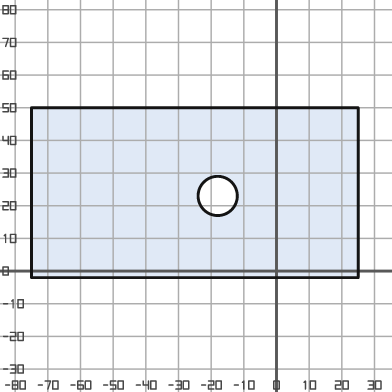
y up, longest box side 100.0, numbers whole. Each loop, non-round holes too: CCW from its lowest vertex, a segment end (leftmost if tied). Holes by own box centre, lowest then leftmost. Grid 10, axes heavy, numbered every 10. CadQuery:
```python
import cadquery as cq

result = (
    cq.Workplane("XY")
    .moveTo(-75.0, -2.0)
    .lineTo(25.0, -2.0)
    .lineTo(25.0, 50.0)
    .lineTo(-75.0, 50.0)
    .close()
    .moveTo(-18.0, 23.0)
    .circle(6.0)
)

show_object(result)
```